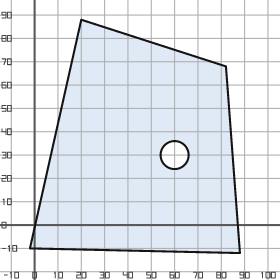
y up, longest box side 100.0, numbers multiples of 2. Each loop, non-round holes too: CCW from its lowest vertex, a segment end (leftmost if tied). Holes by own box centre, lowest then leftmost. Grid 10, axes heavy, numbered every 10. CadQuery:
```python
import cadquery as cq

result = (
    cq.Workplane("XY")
    .moveTo(88.0, -12.0)
    .lineTo(82.0, 68.0)
    .lineTo(20.0, 88.0)
    .lineTo(-2.0, -10.0)
    .close()
    .moveTo(60.0, 30.0)
    .circle(6.0)
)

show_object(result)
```